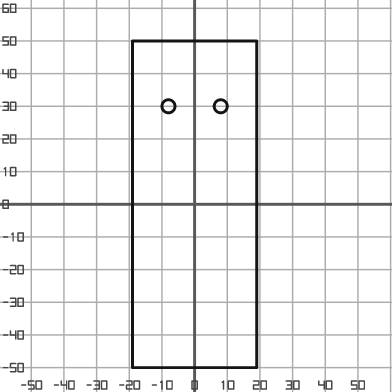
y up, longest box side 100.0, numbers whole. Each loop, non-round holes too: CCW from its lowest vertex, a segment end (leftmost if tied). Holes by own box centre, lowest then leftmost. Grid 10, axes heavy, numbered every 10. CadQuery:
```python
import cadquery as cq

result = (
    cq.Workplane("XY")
    .moveTo(-19.0, -50.0)
    .lineTo(19.0, -50.0)
    .lineTo(19.0, 50.0)
    .lineTo(-19.0, 50.0)
    .close()
    .moveTo(-8.0, 30.0)
    .circle(2.0)
    .moveTo(8.0, 30.0)
    .circle(2.0)
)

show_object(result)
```